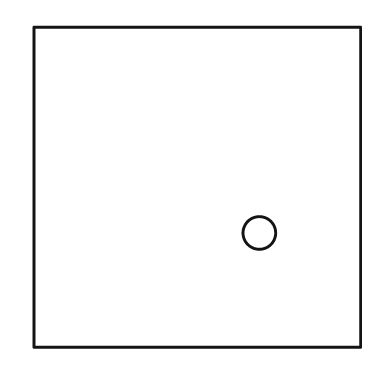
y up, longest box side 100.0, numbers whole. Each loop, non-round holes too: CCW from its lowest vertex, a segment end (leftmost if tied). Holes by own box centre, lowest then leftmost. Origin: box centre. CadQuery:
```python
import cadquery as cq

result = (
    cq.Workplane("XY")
    .moveTo(-50.0, -49.0)
    .lineTo(50.0, -49.0)
    .lineTo(50.0, 49.0)
    .lineTo(-50.0, 49.0)
    .close()
    .moveTo(19.0, -14.0)
    .circle(5.0)
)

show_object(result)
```